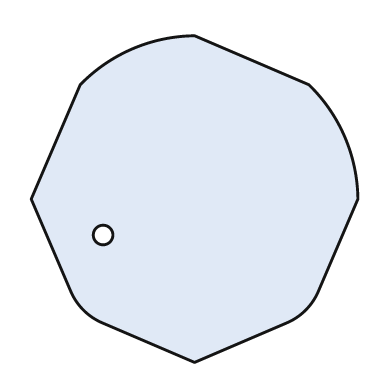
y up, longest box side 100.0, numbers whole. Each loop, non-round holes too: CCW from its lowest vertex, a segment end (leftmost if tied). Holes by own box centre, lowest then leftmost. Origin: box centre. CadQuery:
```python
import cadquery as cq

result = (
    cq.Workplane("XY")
    .moveTo(0.0, -50.0)
    .lineTo(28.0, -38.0)
    .threePointArc((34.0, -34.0), (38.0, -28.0))
    .lineTo(50.0, 0.0)
    .threePointArc((46.0, 19.0), (35.0, 35.0))
    .lineTo(0.0, 50.0)
    .threePointArc((-19.0, 46.0), (-35.0, 35.0))
    .lineTo(-50.0, 0.0)
    .lineTo(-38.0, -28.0)
    .threePointArc((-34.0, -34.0), (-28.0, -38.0))
    .close()
    .moveTo(-28.0, -11.0)
    .circle(3.0)
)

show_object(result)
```